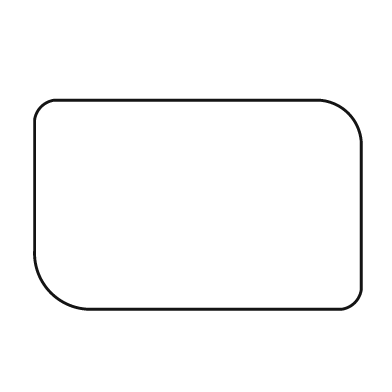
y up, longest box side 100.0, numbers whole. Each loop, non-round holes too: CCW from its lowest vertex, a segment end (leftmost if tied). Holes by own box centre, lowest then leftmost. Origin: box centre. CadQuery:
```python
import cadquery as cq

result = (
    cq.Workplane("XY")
    .moveTo(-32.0, -32.0)
    .lineTo(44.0, -32.0)
    .threePointArc((48.0, -30.0), (50.0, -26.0))
    .lineTo(50.0, 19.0)
    .threePointArc((46.0, 28.0), (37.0, 32.0))
    .lineTo(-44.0, 32.0)
    .threePointArc((-48.0, 30.0), (-50.0, 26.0))
    .lineTo(-50.0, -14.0)
    .threePointArc((-45.0, -27.0), (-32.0, -32.0))
    .close()
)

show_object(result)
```